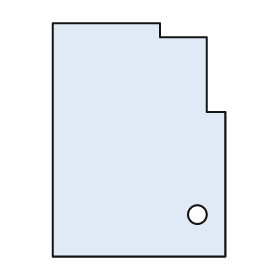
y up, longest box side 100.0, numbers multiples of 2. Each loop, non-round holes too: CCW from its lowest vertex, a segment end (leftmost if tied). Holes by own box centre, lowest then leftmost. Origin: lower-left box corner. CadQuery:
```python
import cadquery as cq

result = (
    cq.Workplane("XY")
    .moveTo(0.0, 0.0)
    .lineTo(74.0, 0.0)
    .lineTo(74.0, 62.0)
    .lineTo(66.0, 62.0)
    .lineTo(66.0, 94.0)
    .lineTo(46.0, 94.0)
    .lineTo(46.0, 100.0)
    .lineTo(0.0, 100.0)
    .close()
    .moveTo(62.0, 18.0)
    .circle(4.0)
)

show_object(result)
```